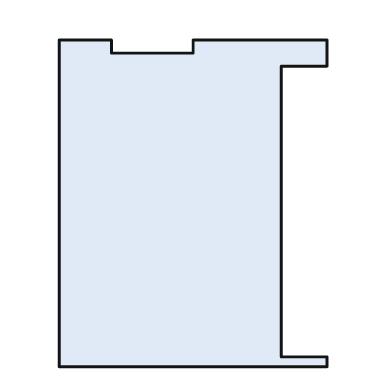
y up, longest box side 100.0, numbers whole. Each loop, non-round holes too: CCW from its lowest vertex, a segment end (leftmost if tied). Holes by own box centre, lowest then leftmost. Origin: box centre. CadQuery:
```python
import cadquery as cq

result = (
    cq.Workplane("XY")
    .moveTo(-41.0, -50.0)
    .lineTo(41.0, -50.0)
    .lineTo(41.0, -47.0)
    .lineTo(27.0, -47.0)
    .lineTo(27.0, 42.0)
    .lineTo(41.0, 42.0)
    .lineTo(41.0, 50.0)
    .lineTo(0.0, 50.0)
    .lineTo(0.0, 46.0)
    .lineTo(-25.0, 46.0)
    .lineTo(-25.0, 50.0)
    .lineTo(-41.0, 50.0)
    .close()
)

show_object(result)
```